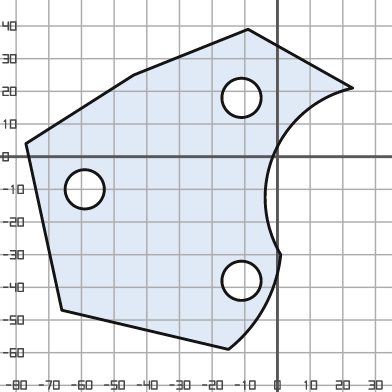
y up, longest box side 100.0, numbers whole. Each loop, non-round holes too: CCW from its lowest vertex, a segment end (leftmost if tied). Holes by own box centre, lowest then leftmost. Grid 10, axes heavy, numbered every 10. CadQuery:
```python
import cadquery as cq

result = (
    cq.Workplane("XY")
    .moveTo(-15.0, -59.0)
    .threePointArc((-4.0, -46.0), (1.0, -30.0))
    .threePointArc((-1.0, 1.0), (23.0, 21.0))
    .lineTo(-9.0, 39.0)
    .lineTo(-44.0, 25.0)
    .lineTo(-77.0, 4.0)
    .lineTo(-66.0, -47.0)
    .close()
    .moveTo(-11.0, -38.0)
    .circle(6.0)
    .moveTo(-59.0, -10.0)
    .circle(6.0)
    .moveTo(-11.0, 18.0)
    .circle(6.0)
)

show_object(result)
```